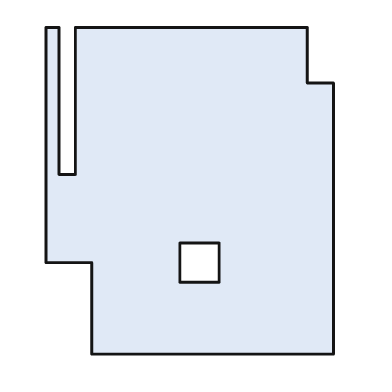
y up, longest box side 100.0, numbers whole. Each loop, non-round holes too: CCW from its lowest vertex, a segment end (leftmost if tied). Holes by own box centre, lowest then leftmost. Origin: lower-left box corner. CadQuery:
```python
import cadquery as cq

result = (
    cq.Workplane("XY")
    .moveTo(14.0, 0.0)
    .lineTo(88.0, 0.0)
    .lineTo(88.0, 83.0)
    .lineTo(80.0, 83.0)
    .lineTo(80.0, 100.0)
    .lineTo(9.0, 100.0)
    .lineTo(9.0, 55.0)
    .lineTo(4.0, 55.0)
    .lineTo(4.0, 100.0)
    .lineTo(0.0, 100.0)
    .lineTo(0.0, 28.0)
    .lineTo(14.0, 28.0)
    .close()
    .moveTo(41.0, 22.0)
    .lineTo(53.0, 22.0)
    .lineTo(53.0, 34.0)
    .lineTo(41.0, 34.0)
    .close()
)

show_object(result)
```